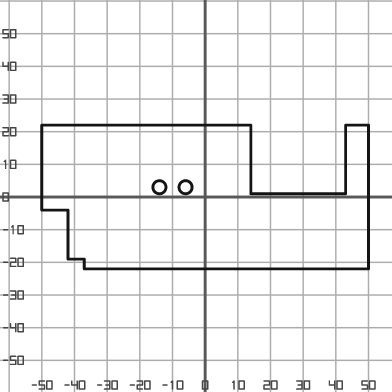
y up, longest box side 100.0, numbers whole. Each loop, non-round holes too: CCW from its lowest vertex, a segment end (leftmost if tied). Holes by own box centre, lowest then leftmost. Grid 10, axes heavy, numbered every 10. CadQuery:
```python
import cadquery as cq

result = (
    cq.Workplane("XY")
    .moveTo(-37.0, -22.0)
    .lineTo(50.0, -22.0)
    .lineTo(50.0, 22.0)
    .lineTo(43.0, 22.0)
    .lineTo(43.0, 1.0)
    .lineTo(14.0, 1.0)
    .lineTo(14.0, 22.0)
    .lineTo(-50.0, 22.0)
    .lineTo(-50.0, -4.0)
    .lineTo(-42.0, -4.0)
    .lineTo(-42.0, -19.0)
    .lineTo(-37.0, -19.0)
    .close()
    .moveTo(-14.0, 3.0)
    .circle(2.0)
    .moveTo(-6.0, 3.0)
    .circle(2.0)
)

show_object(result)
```